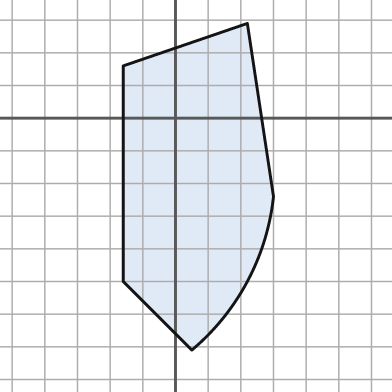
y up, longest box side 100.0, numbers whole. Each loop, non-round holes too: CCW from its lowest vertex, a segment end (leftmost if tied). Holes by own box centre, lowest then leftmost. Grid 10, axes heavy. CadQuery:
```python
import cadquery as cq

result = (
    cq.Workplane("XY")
    .moveTo(5.0, -71.0)
    .threePointArc((22.0, -50.0), (30.0, -24.0))
    .lineTo(22.0, 29.0)
    .lineTo(-16.0, 16.0)
    .lineTo(-16.0, -50.0)
    .close()
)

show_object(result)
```